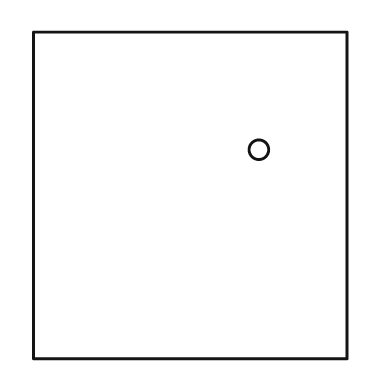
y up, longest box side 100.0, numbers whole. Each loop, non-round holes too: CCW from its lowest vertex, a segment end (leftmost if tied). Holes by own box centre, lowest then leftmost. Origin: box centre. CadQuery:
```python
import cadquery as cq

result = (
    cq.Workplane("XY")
    .moveTo(-48.0, -50.0)
    .lineTo(48.0, -50.0)
    .lineTo(48.0, 50.0)
    .lineTo(-48.0, 50.0)
    .close()
    .moveTo(21.0, 14.0)
    .circle(3.0)
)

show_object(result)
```